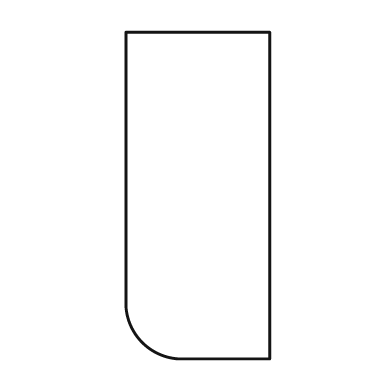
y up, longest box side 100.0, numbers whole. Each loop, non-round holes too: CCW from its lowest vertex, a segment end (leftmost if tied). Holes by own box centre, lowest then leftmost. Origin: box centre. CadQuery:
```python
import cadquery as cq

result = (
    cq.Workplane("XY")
    .moveTo(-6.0, -50.0)
    .lineTo(22.0, -50.0)
    .lineTo(22.0, 50.0)
    .lineTo(-22.0, 50.0)
    .lineTo(-22.0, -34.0)
    .threePointArc((-17.0, -45.0), (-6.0, -50.0))
    .close()
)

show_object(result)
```